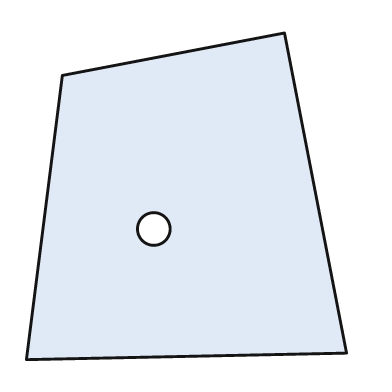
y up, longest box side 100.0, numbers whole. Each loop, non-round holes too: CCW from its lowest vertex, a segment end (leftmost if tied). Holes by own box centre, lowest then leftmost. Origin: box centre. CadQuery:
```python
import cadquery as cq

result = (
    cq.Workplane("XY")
    .moveTo(-49.0, -50.0)
    .lineTo(49.0, -48.0)
    .lineTo(30.0, 50.0)
    .lineTo(-38.0, 37.0)
    .close()
    .moveTo(-10.0, -10.0)
    .circle(5.0)
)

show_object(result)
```